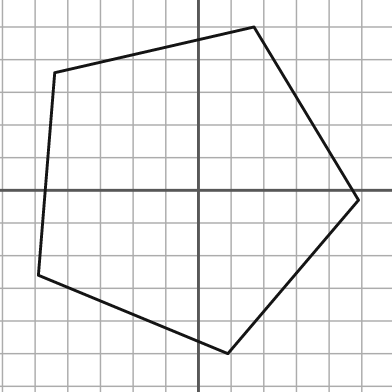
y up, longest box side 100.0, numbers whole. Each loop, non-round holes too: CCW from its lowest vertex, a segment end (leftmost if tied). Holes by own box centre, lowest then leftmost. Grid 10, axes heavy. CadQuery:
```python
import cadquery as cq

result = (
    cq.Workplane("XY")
    .moveTo(9.0, -50.0)
    .lineTo(49.0, -3.0)
    .lineTo(17.0, 50.0)
    .lineTo(-44.0, 36.0)
    .lineTo(-49.0, -26.0)
    .close()
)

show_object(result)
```